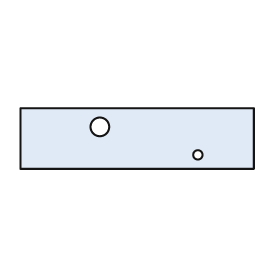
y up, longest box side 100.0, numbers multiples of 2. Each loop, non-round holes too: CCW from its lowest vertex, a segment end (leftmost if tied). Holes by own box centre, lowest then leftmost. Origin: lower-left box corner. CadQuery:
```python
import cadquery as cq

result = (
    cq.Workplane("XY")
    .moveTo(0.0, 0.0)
    .lineTo(100.0, 0.0)
    .lineTo(100.0, 26.0)
    .lineTo(0.0, 26.0)
    .close()
    .moveTo(76.0, 6.0)
    .circle(2.0)
    .moveTo(34.0, 18.0)
    .circle(4.0)
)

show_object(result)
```